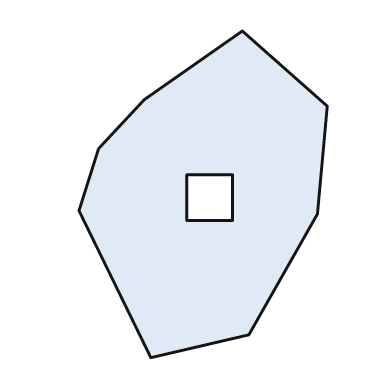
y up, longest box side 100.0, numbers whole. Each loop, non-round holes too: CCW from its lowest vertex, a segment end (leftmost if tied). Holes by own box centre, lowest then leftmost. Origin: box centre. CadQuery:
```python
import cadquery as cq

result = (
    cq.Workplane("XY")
    .moveTo(-16.0, -50.0)
    .lineTo(14.0, -43.0)
    .lineTo(35.0, -6.0)
    .lineTo(38.0, 27.0)
    .lineTo(12.0, 50.0)
    .lineTo(-18.0, 29.0)
    .lineTo(-32.0, 14.0)
    .lineTo(-38.0, -5.0)
    .close()
    .moveTo(-5.0, -8.0)
    .lineTo(9.0, -8.0)
    .lineTo(9.0, 6.0)
    .lineTo(-5.0, 6.0)
    .close()
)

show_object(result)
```